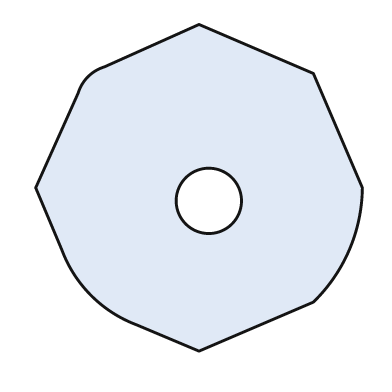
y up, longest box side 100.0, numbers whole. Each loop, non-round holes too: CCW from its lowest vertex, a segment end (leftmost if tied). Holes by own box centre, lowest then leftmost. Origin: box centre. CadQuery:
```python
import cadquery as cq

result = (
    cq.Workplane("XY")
    .moveTo(0.0, -50.0)
    .lineTo(35.0, -35.0)
    .threePointArc((46.0, -19.0), (50.0, 0.0))
    .lineTo(35.0, 35.0)
    .lineTo(0.0, 50.0)
    .lineTo(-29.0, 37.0)
    .threePointArc((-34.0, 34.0), (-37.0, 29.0))
    .lineTo(-50.0, 0.0)
    .lineTo(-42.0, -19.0)
    .threePointArc((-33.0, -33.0), (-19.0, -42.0))
    .close()
    .moveTo(3.0, -4.0)
    .circle(10.0)
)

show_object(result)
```